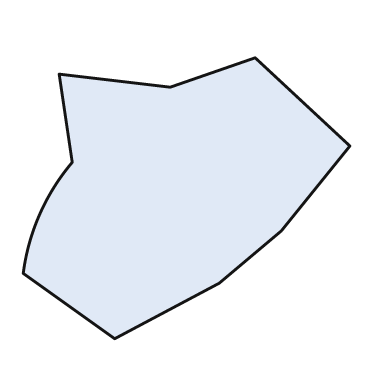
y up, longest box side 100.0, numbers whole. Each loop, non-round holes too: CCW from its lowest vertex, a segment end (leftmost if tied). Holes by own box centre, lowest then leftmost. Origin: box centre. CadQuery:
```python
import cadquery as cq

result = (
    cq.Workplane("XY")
    .moveTo(-22.0, -43.0)
    .lineTo(10.0, -26.0)
    .lineTo(29.0, -10.0)
    .lineTo(50.0, 16.0)
    .lineTo(21.0, 43.0)
    .lineTo(-5.0, 34.0)
    .lineTo(-39.0, 38.0)
    .lineTo(-35.0, 11.0)
    .threePointArc((-45.0, -5.0), (-50.0, -23.0))
    .close()
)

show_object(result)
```